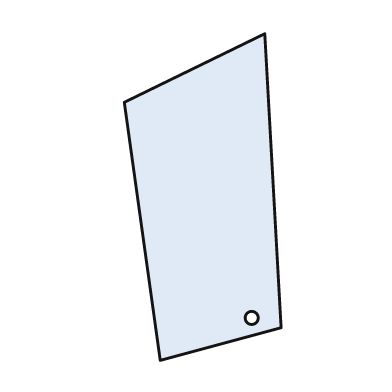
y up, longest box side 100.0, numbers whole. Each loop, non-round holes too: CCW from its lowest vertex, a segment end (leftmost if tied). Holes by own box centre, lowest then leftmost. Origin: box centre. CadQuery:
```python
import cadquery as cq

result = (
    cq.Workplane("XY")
    .moveTo(-13.0, -50.0)
    .lineTo(24.0, -40.0)
    .lineTo(19.0, 50.0)
    .lineTo(-24.0, 29.0)
    .close()
    .moveTo(15.0, -37.0)
    .circle(2.0)
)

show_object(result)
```